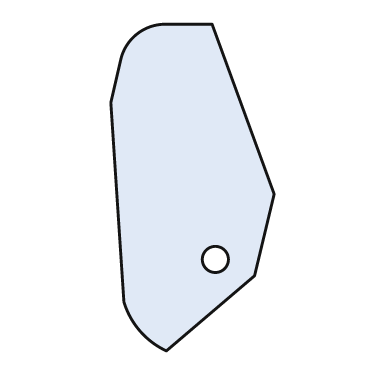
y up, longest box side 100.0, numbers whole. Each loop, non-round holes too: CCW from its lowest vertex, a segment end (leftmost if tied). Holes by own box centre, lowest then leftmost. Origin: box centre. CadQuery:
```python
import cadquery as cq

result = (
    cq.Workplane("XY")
    .moveTo(-8.0, -50.0)
    .lineTo(19.0, -27.0)
    .lineTo(25.0, -2.0)
    .lineTo(6.0, 50.0)
    .lineTo(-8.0, 50.0)
    .threePointArc((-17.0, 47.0), (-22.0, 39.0))
    .lineTo(-25.0, 26.0)
    .lineTo(-21.0, -35.0)
    .threePointArc((-16.0, -44.0), (-8.0, -50.0))
    .close()
    .moveTo(7.0, -22.0)
    .circle(4.0)
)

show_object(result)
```